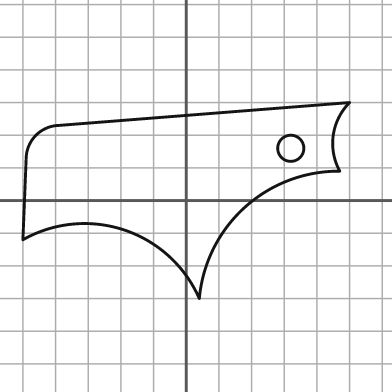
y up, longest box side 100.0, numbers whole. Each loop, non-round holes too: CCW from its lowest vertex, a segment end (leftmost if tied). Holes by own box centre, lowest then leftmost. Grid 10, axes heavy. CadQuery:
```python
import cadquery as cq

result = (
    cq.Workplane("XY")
    .moveTo(4.0, -30.0)
    .threePointArc((18.0, -2.0), (47.0, 9.0))
    .threePointArc((45.0, 20.0), (50.0, 30.0))
    .lineTo(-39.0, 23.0)
    .threePointArc((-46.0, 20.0), (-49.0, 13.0))
    .lineTo(-50.0, -12.0)
    .threePointArc((-19.0, -9.0), (4.0, -30.0))
    .close()
    .moveTo(32.0, 16.0)
    .circle(4.0)
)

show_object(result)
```